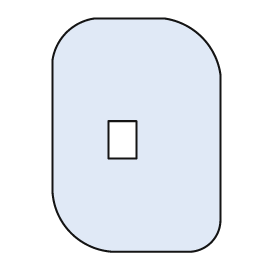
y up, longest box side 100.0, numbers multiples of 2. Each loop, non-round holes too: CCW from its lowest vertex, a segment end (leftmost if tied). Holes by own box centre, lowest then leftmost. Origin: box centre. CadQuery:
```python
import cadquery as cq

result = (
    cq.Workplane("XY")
    .moveTo(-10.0, -50.0)
    .lineTo(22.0, -50.0)
    .threePointArc((32.0, -46.0), (36.0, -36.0))
    .lineTo(36.0, 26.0)
    .threePointArc((28.0, 42.0), (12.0, 50.0))
    .lineTo(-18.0, 50.0)
    .threePointArc((-30.0, 44.0), (-36.0, 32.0))
    .lineTo(-36.0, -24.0)
    .threePointArc((-28.0, -42.0), (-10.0, -50.0))
    .close()
    .moveTo(-12.0, -10.0)
    .lineTo(0.0, -10.0)
    .lineTo(0.0, 6.0)
    .lineTo(-12.0, 6.0)
    .close()
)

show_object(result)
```